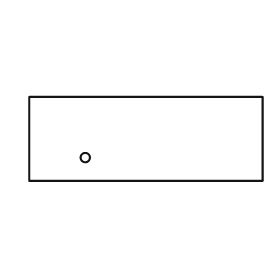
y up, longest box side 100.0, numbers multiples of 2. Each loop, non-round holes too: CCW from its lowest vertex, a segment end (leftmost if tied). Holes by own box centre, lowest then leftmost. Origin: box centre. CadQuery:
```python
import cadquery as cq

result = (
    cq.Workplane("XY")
    .moveTo(-50.0, -18.0)
    .lineTo(50.0, -18.0)
    .lineTo(50.0, 18.0)
    .lineTo(-50.0, 18.0)
    .close()
    .moveTo(-26.0, -8.0)
    .circle(2.0)
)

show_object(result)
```